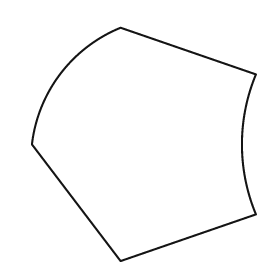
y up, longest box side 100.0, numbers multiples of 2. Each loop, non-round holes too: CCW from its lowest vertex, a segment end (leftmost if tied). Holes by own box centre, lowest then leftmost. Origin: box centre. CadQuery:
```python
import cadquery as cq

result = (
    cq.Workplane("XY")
    .moveTo(-10.0, -50.0)
    .lineTo(48.0, -30.0)
    .threePointArc((42.0, 0.0), (48.0, 30.0))
    .lineTo(-10.0, 50.0)
    .threePointArc((-36.0, 30.0), (-48.0, 0.0))
    .close()
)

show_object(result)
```